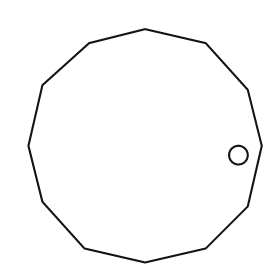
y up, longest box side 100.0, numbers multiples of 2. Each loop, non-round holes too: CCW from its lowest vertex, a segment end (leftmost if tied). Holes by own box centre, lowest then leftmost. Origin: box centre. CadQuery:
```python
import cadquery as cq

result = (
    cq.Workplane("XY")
    .moveTo(0.0, -50.0)
    .lineTo(26.0, -44.0)
    .lineTo(44.0, -26.0)
    .lineTo(50.0, 0.0)
    .lineTo(44.0, 24.0)
    .lineTo(26.0, 44.0)
    .lineTo(0.0, 50.0)
    .lineTo(-24.0, 44.0)
    .lineTo(-44.0, 26.0)
    .lineTo(-50.0, 0.0)
    .lineTo(-44.0, -24.0)
    .lineTo(-26.0, -44.0)
    .close()
    .moveTo(40.0, -4.0)
    .circle(4.0)
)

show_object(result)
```